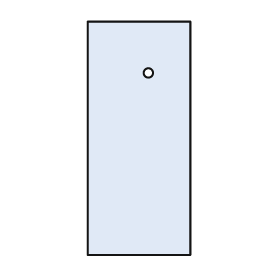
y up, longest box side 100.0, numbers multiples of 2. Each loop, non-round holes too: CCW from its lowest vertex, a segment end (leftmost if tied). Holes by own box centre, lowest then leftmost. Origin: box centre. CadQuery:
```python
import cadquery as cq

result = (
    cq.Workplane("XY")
    .moveTo(-22.0, -50.0)
    .lineTo(22.0, -50.0)
    .lineTo(22.0, 50.0)
    .lineTo(-22.0, 50.0)
    .close()
    .moveTo(4.0, 28.0)
    .circle(2.0)
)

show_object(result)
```